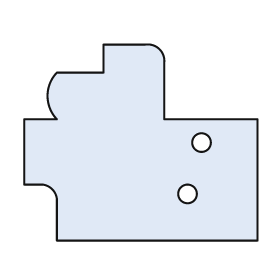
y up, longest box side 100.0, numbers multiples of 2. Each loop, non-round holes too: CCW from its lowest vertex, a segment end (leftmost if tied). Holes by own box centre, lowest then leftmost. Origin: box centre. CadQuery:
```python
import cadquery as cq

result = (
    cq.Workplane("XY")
    .moveTo(-36.0, -42.0)
    .lineTo(50.0, -42.0)
    .lineTo(50.0, 10.0)
    .lineTo(10.0, 10.0)
    .lineTo(10.0, 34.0)
    .threePointArc((8.0, 40.0), (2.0, 42.0))
    .lineTo(-16.0, 42.0)
    .lineTo(-16.0, 30.0)
    .lineTo(-36.0, 30.0)
    .threePointArc((-40.0, 20.0), (-36.0, 10.0))
    .lineTo(-50.0, 10.0)
    .lineTo(-50.0, -18.0)
    .lineTo(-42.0, -18.0)
    .threePointArc((-38.0, -20.0), (-36.0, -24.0))
    .close()
    .moveTo(20.0, -22.0)
    .circle(4.0)
    .moveTo(26.0, 0.0)
    .circle(4.0)
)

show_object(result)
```